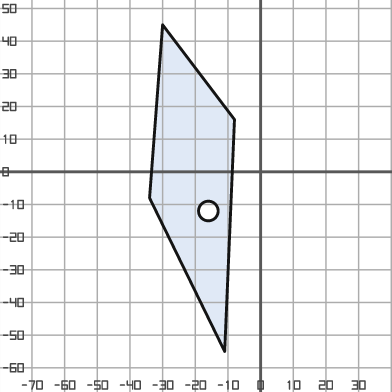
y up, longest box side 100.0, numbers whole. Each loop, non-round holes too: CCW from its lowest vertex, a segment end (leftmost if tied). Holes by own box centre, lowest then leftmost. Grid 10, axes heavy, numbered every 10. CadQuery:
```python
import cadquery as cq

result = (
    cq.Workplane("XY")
    .moveTo(-11.0, -55.0)
    .lineTo(-8.0, 16.0)
    .lineTo(-30.0, 45.0)
    .lineTo(-34.0, -8.0)
    .close()
    .moveTo(-16.0, -12.0)
    .circle(3.0)
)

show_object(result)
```